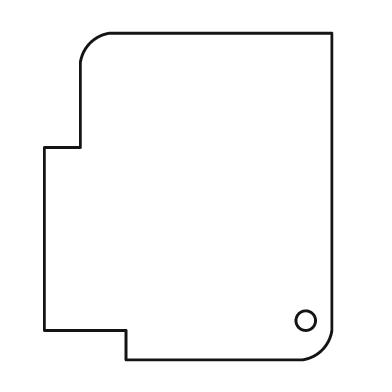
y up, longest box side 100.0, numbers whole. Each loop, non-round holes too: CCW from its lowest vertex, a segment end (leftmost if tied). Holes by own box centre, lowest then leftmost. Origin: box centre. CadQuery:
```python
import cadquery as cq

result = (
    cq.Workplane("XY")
    .moveTo(-19.0, -50.0)
    .lineTo(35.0, -50.0)
    .threePointArc((41.0, -47.0), (44.0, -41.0))
    .lineTo(44.0, 50.0)
    .lineTo(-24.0, 50.0)
    .threePointArc((-30.0, 47.0), (-33.0, 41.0))
    .lineTo(-33.0, 15.0)
    .lineTo(-44.0, 15.0)
    .lineTo(-44.0, -41.0)
    .lineTo(-19.0, -41.0)
    .close()
    .moveTo(36.0, -38.0)
    .circle(3.0)
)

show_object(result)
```